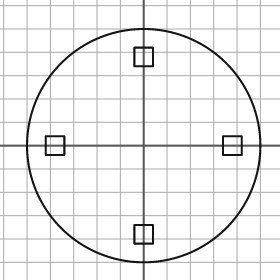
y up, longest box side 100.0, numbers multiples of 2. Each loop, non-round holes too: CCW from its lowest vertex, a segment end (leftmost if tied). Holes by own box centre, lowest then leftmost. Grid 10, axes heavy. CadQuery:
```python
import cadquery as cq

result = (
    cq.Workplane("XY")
    .moveTo(0.0, 0.0)
    .circle(50.0)
    .moveTo(-4.0, -42.0)
    .lineTo(4.0, -42.0)
    .lineTo(4.0, -34.0)
    .lineTo(-4.0, -34.0)
    .close()
    .moveTo(-42.0, -4.0)
    .lineTo(-34.0, -4.0)
    .lineTo(-34.0, 4.0)
    .lineTo(-42.0, 4.0)
    .close()
    .moveTo(34.0, -4.0)
    .lineTo(42.0, -4.0)
    .lineTo(42.0, 4.0)
    .lineTo(34.0, 4.0)
    .close()
    .moveTo(-4.0, 34.0)
    .lineTo(4.0, 34.0)
    .lineTo(4.0, 42.0)
    .lineTo(-4.0, 42.0)
    .close()
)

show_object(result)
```